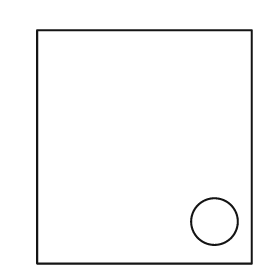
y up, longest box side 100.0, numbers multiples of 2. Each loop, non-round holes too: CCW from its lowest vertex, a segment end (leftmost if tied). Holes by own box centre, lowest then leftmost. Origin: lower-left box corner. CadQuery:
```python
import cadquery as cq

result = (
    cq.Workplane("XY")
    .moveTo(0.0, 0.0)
    .lineTo(92.0, 0.0)
    .lineTo(92.0, 100.0)
    .lineTo(0.0, 100.0)
    .close()
    .moveTo(76.0, 18.0)
    .circle(10.0)
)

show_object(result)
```